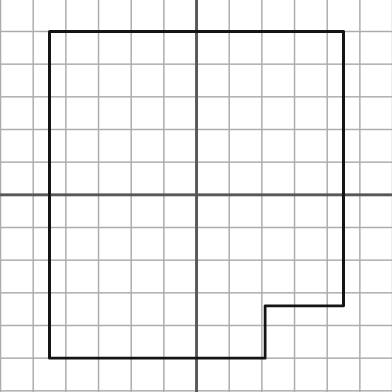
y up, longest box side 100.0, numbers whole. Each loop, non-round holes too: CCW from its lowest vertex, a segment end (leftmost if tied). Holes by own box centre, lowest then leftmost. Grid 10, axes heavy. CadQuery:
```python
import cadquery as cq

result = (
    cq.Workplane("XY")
    .moveTo(-45.0, -50.0)
    .lineTo(21.0, -50.0)
    .lineTo(21.0, -34.0)
    .lineTo(45.0, -34.0)
    .lineTo(45.0, 50.0)
    .lineTo(-45.0, 50.0)
    .close()
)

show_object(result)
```